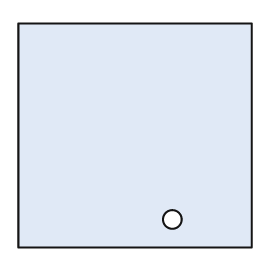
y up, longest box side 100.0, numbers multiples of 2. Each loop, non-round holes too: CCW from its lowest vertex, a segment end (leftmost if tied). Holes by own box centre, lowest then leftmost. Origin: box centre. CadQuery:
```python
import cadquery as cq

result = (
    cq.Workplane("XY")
    .moveTo(-50.0, -48.0)
    .lineTo(50.0, -48.0)
    .lineTo(50.0, 48.0)
    .lineTo(-50.0, 48.0)
    .close()
    .moveTo(16.0, -36.0)
    .circle(4.0)
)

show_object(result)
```